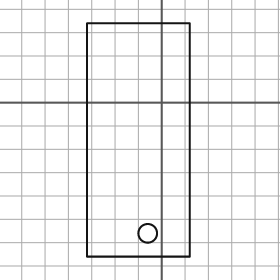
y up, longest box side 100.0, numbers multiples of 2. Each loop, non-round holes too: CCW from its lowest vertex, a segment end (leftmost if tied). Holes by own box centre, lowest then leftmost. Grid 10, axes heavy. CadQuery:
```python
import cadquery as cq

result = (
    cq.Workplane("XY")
    .moveTo(-32.0, -66.0)
    .lineTo(12.0, -66.0)
    .lineTo(12.0, 34.0)
    .lineTo(-32.0, 34.0)
    .close()
    .moveTo(-6.0, -56.0)
    .circle(4.0)
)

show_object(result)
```